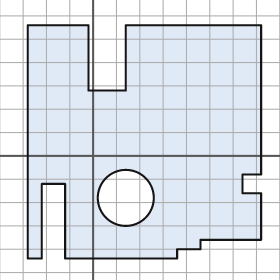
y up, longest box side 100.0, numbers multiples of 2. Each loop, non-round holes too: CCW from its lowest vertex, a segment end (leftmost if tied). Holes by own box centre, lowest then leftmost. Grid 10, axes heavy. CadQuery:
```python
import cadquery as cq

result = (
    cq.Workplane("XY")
    .moveTo(-28.0, -44.0)
    .lineTo(-22.0, -44.0)
    .lineTo(-22.0, -12.0)
    .lineTo(-12.0, -12.0)
    .lineTo(-12.0, -44.0)
    .lineTo(36.0, -44.0)
    .lineTo(36.0, -40.0)
    .lineTo(46.0, -40.0)
    .lineTo(46.0, -36.0)
    .lineTo(72.0, -36.0)
    .lineTo(72.0, -16.0)
    .lineTo(64.0, -16.0)
    .lineTo(64.0, -8.0)
    .lineTo(72.0, -8.0)
    .lineTo(72.0, 56.0)
    .lineTo(14.0, 56.0)
    .lineTo(14.0, 28.0)
    .lineTo(-2.0, 28.0)
    .lineTo(-2.0, 56.0)
    .lineTo(-28.0, 56.0)
    .close()
    .moveTo(14.0, -18.0)
    .circle(12.0)
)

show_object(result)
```